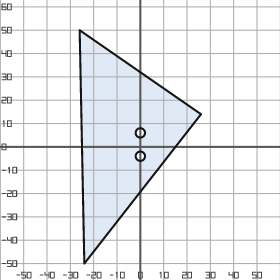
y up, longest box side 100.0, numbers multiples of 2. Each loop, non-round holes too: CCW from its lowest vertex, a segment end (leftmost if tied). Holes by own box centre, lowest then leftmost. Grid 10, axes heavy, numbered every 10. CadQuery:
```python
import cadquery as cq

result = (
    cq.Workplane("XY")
    .moveTo(-24.0, -50.0)
    .lineTo(26.0, 14.0)
    .lineTo(-26.0, 50.0)
    .close()
    .moveTo(0.0, -4.0)
    .circle(2.0)
    .moveTo(0.0, 6.0)
    .circle(2.0)
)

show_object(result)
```